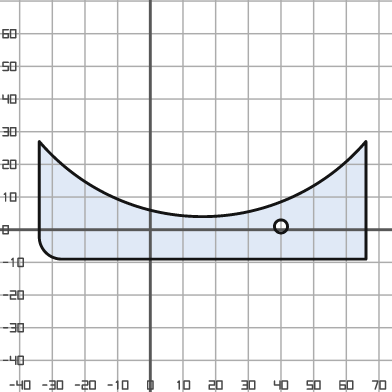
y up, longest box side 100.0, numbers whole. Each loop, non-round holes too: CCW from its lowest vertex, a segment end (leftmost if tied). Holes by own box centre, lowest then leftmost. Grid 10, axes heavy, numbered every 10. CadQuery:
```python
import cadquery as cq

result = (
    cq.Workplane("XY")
    .moveTo(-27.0, -9.0)
    .lineTo(66.0, -9.0)
    .lineTo(66.0, 27.0)
    .threePointArc((16.0, 4.0), (-34.0, 27.0))
    .lineTo(-34.0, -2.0)
    .threePointArc((-32.0, -7.0), (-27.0, -9.0))
    .close()
    .moveTo(40.0, 1.0)
    .circle(2.0)
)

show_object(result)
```